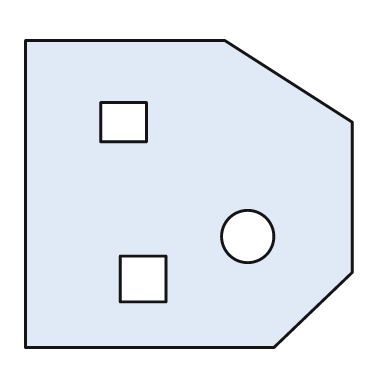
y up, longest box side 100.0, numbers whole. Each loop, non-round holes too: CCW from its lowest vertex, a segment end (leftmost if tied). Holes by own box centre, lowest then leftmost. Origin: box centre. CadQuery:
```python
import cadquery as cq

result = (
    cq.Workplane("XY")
    .moveTo(-50.0, -47.0)
    .lineTo(26.0, -47.0)
    .lineTo(50.0, -24.0)
    .lineTo(50.0, 22.0)
    .lineTo(11.0, 47.0)
    .lineTo(-50.0, 47.0)
    .close()
    .moveTo(-21.0, -33.0)
    .lineTo(-7.0, -33.0)
    .lineTo(-7.0, -19.0)
    .lineTo(-21.0, -19.0)
    .close()
    .moveTo(18.0, -13.0)
    .circle(8.0)
    .moveTo(-27.0, 16.0)
    .lineTo(-13.0, 16.0)
    .lineTo(-13.0, 28.0)
    .lineTo(-27.0, 28.0)
    .close()
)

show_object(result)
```